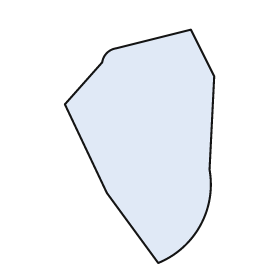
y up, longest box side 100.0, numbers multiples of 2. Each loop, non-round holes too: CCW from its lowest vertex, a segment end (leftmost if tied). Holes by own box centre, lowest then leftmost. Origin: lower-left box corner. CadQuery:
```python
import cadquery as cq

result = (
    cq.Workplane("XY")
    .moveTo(40.0, 0.0)
    .threePointArc((58.0, 16.0), (62.0, 40.0))
    .lineTo(64.0, 80.0)
    .lineTo(54.0, 100.0)
    .lineTo(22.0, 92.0)
    .threePointArc((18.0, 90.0), (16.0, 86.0))
    .lineTo(0.0, 68.0)
    .lineTo(18.0, 30.0)
    .close()
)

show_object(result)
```